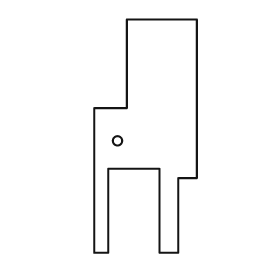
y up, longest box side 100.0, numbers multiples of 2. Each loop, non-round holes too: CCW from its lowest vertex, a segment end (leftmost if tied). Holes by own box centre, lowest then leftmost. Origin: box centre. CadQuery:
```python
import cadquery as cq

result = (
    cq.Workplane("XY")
    .moveTo(-22.0, -50.0)
    .lineTo(-16.0, -50.0)
    .lineTo(-16.0, -14.0)
    .lineTo(6.0, -14.0)
    .lineTo(6.0, -50.0)
    .lineTo(14.0, -50.0)
    .lineTo(14.0, -18.0)
    .lineTo(22.0, -18.0)
    .lineTo(22.0, 50.0)
    .lineTo(-8.0, 50.0)
    .lineTo(-8.0, 12.0)
    .lineTo(-22.0, 12.0)
    .close()
    .moveTo(-12.0, -2.0)
    .circle(2.0)
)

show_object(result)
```